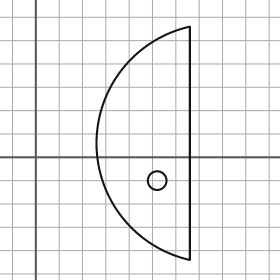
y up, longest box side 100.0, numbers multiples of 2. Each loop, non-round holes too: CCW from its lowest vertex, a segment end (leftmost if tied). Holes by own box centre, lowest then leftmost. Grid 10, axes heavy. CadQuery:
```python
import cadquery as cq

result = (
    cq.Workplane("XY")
    .moveTo(66.0, -44.0)
    .lineTo(66.0, 56.0)
    .threePointArc((26.0, 6.0), (66.0, -44.0))
    .close()
    .moveTo(52.0, -10.0)
    .circle(4.0)
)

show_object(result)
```